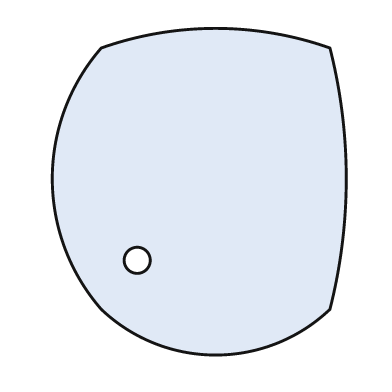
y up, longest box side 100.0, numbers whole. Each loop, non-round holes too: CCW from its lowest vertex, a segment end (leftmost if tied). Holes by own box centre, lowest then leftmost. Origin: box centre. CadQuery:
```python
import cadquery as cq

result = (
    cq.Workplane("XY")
    .moveTo(-30.0, -36.0)
    .threePointArc((5.0, -50.0), (40.0, -36.0))
    .threePointArc((45.0, 4.0), (40.0, 44.0))
    .threePointArc((5.0, 50.0), (-30.0, 44.0))
    .threePointArc((-45.0, 4.0), (-30.0, -36.0))
    .close()
    .moveTo(-19.0, -21.0)
    .circle(4.0)
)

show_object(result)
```